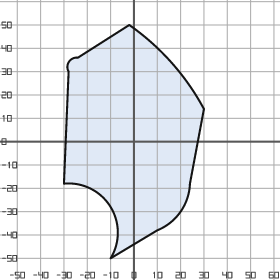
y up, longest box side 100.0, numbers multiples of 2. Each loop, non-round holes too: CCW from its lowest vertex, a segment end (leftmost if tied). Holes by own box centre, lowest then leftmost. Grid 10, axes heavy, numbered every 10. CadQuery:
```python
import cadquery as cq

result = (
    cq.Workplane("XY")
    .moveTo(-10.0, -50.0)
    .lineTo(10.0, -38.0)
    .threePointArc((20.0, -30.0), (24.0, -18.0))
    .lineTo(30.0, 14.0)
    .threePointArc((16.0, 34.0), (-2.0, 50.0))
    .lineTo(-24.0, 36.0)
    .threePointArc((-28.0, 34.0), (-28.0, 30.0))
    .lineTo(-30.0, -18.0)
    .threePointArc((-10.0, -28.0), (-10.0, -50.0))
    .close()
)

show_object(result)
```